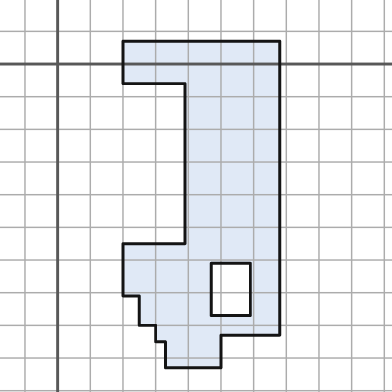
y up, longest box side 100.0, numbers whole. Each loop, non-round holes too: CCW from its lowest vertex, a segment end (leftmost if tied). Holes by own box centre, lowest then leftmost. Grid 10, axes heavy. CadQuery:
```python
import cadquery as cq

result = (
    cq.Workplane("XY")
    .moveTo(33.0, -93.0)
    .lineTo(50.0, -93.0)
    .lineTo(50.0, -83.0)
    .lineTo(68.0, -83.0)
    .lineTo(68.0, 7.0)
    .lineTo(20.0, 7.0)
    .lineTo(20.0, -6.0)
    .lineTo(39.0, -6.0)
    .lineTo(39.0, -55.0)
    .lineTo(20.0, -55.0)
    .lineTo(20.0, -71.0)
    .lineTo(25.0, -71.0)
    .lineTo(25.0, -80.0)
    .lineTo(30.0, -80.0)
    .lineTo(30.0, -85.0)
    .lineTo(33.0, -85.0)
    .close()
    .moveTo(47.0, -77.0)
    .lineTo(59.0, -77.0)
    .lineTo(59.0, -61.0)
    .lineTo(47.0, -61.0)
    .close()
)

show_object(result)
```